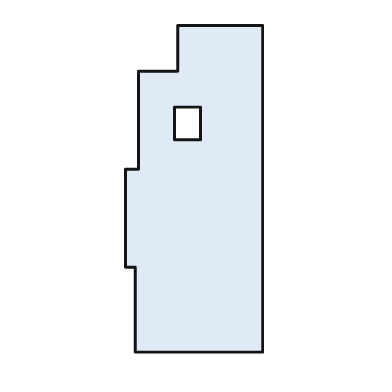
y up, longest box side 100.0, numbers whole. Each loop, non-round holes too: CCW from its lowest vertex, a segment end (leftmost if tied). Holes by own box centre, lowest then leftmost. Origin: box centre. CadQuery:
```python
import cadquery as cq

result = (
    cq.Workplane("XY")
    .moveTo(-18.0, -50.0)
    .lineTo(21.0, -50.0)
    .lineTo(21.0, 50.0)
    .lineTo(-5.0, 50.0)
    .lineTo(-5.0, 36.0)
    .lineTo(-17.0, 36.0)
    .lineTo(-17.0, 6.0)
    .lineTo(-21.0, 6.0)
    .lineTo(-21.0, -24.0)
    .lineTo(-18.0, -24.0)
    .close()
    .moveTo(-6.0, 15.0)
    .lineTo(2.0, 15.0)
    .lineTo(2.0, 25.0)
    .lineTo(-6.0, 25.0)
    .close()
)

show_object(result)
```